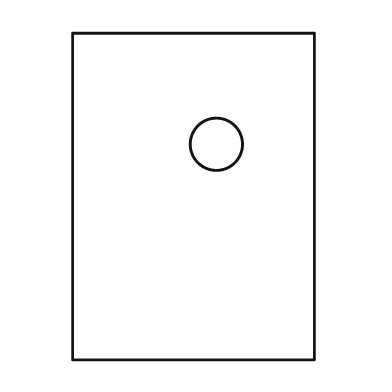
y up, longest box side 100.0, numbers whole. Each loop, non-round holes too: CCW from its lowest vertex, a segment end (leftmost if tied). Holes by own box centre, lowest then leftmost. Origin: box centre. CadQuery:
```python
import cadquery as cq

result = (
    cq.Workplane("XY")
    .moveTo(-37.0, -50.0)
    .lineTo(37.0, -50.0)
    .lineTo(37.0, 50.0)
    .lineTo(-37.0, 50.0)
    .close()
    .moveTo(7.0, 16.0)
    .circle(8.0)
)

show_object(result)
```